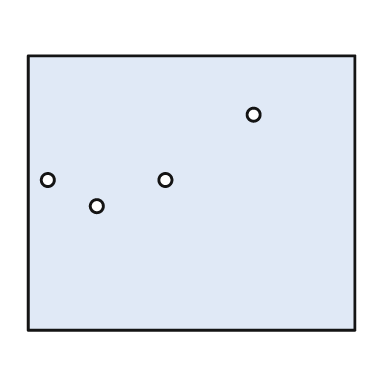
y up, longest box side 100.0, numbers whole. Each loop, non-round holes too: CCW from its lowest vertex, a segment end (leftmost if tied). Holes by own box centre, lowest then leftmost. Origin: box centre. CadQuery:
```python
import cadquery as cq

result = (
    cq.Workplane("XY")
    .moveTo(-50.0, -42.0)
    .lineTo(50.0, -42.0)
    .lineTo(50.0, 42.0)
    .lineTo(-50.0, 42.0)
    .close()
    .moveTo(-29.0, -4.0)
    .circle(2.0)
    .moveTo(-44.0, 4.0)
    .circle(2.0)
    .moveTo(-8.0, 4.0)
    .circle(2.0)
    .moveTo(19.0, 24.0)
    .circle(2.0)
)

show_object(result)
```